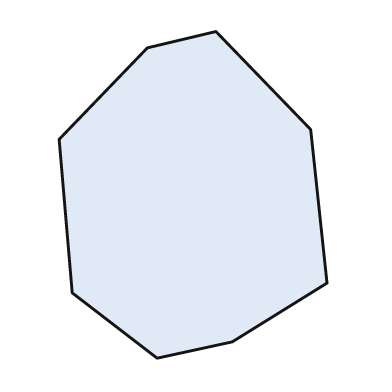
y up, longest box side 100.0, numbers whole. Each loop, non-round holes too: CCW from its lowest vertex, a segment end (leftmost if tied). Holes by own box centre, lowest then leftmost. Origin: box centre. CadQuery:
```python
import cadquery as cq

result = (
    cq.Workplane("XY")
    .moveTo(-11.0, -50.0)
    .lineTo(12.0, -45.0)
    .lineTo(41.0, -27.0)
    .lineTo(36.0, 20.0)
    .lineTo(7.0, 50.0)
    .lineTo(-14.0, 45.0)
    .lineTo(-41.0, 17.0)
    .lineTo(-37.0, -30.0)
    .close()
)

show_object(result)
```